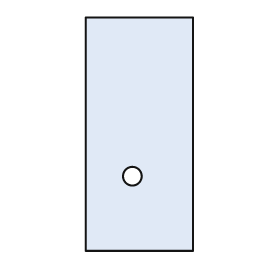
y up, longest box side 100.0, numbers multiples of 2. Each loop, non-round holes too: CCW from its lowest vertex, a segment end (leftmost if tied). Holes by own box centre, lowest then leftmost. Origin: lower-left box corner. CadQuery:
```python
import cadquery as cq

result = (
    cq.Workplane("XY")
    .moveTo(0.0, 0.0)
    .lineTo(46.0, 0.0)
    .lineTo(46.0, 100.0)
    .lineTo(0.0, 100.0)
    .close()
    .moveTo(20.0, 32.0)
    .circle(4.0)
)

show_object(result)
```